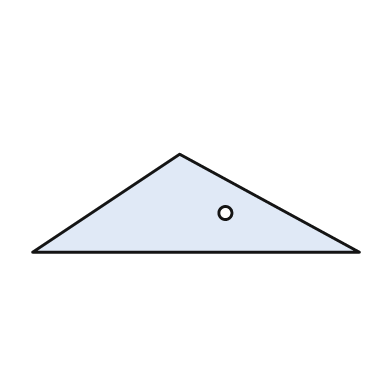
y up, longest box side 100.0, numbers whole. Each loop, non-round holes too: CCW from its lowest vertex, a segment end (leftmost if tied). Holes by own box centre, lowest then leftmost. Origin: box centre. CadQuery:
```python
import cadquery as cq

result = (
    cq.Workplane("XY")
    .moveTo(-50.0, -15.0)
    .lineTo(50.0, -15.0)
    .lineTo(-5.0, 15.0)
    .close()
    .moveTo(9.0, -3.0)
    .circle(2.0)
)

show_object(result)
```